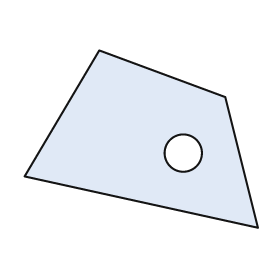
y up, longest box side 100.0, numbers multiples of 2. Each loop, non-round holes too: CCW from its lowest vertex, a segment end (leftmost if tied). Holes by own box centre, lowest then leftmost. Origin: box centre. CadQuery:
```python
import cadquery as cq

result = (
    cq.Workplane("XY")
    .moveTo(50.0, -38.0)
    .lineTo(36.0, 18.0)
    .lineTo(-18.0, 38.0)
    .lineTo(-50.0, -16.0)
    .close()
    .moveTo(18.0, -6.0)
    .circle(8.0)
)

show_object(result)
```